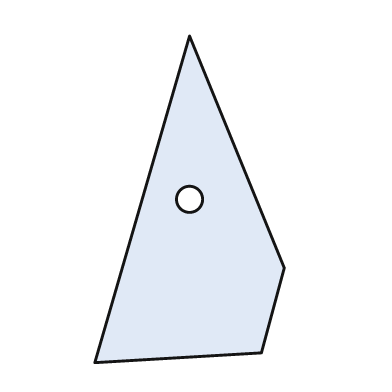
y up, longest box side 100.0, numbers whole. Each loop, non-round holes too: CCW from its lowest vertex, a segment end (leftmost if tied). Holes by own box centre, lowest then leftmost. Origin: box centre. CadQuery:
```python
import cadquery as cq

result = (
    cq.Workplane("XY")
    .moveTo(-29.0, -50.0)
    .lineTo(22.0, -47.0)
    .lineTo(29.0, -21.0)
    .lineTo(0.0, 50.0)
    .close()
    .moveTo(0.0, 0.0)
    .circle(4.0)
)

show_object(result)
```